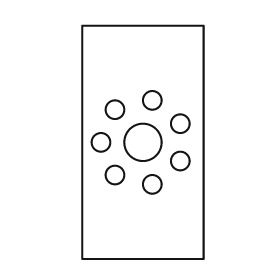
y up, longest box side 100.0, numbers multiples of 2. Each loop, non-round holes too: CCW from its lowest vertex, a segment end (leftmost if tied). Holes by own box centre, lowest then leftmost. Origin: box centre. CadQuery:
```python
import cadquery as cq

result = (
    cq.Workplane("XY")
    .moveTo(-26.0, -50.0)
    .lineTo(26.0, -50.0)
    .lineTo(26.0, 50.0)
    .lineTo(-26.0, 50.0)
    .close()
    .moveTo(4.0, -18.0)
    .circle(4.0)
    .moveTo(-12.0, -14.0)
    .circle(4.0)
    .moveTo(16.0, -8.0)
    .circle(4.0)
    .moveTo(-18.0, 0.0)
    .circle(4.0)
    .moveTo(0.0, 0.0)
    .circle(8.0)
    .moveTo(16.0, 8.0)
    .circle(4.0)
    .moveTo(-12.0, 14.0)
    .circle(4.0)
    .moveTo(4.0, 18.0)
    .circle(4.0)
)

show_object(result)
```